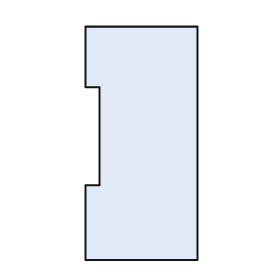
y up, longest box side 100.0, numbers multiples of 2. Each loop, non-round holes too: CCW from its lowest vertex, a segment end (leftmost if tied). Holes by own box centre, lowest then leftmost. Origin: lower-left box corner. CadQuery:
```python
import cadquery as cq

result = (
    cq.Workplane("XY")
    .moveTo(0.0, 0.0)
    .lineTo(48.0, 0.0)
    .lineTo(48.0, 100.0)
    .lineTo(0.0, 100.0)
    .lineTo(0.0, 74.0)
    .lineTo(6.0, 74.0)
    .lineTo(6.0, 32.0)
    .lineTo(0.0, 32.0)
    .close()
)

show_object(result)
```